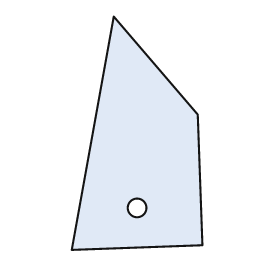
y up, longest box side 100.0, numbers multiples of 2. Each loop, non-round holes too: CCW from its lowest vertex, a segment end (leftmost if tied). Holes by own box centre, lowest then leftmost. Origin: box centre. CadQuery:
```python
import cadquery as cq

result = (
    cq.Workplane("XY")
    .moveTo(-28.0, -50.0)
    .lineTo(28.0, -48.0)
    .lineTo(26.0, 8.0)
    .lineTo(-10.0, 50.0)
    .close()
    .moveTo(0.0, -32.0)
    .circle(4.0)
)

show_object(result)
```